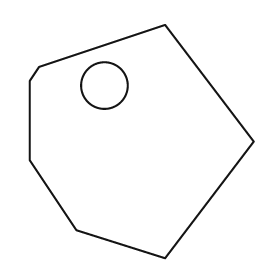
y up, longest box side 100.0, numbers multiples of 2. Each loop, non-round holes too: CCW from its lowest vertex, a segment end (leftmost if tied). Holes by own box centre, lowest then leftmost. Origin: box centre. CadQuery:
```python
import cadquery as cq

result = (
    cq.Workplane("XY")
    .moveTo(10.0, -50.0)
    .lineTo(48.0, 0.0)
    .lineTo(10.0, 50.0)
    .lineTo(-44.0, 32.0)
    .lineTo(-48.0, 26.0)
    .lineTo(-48.0, -8.0)
    .lineTo(-28.0, -38.0)
    .close()
    .moveTo(-16.0, 24.0)
    .circle(10.0)
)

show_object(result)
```